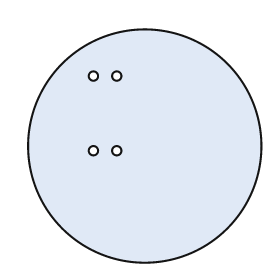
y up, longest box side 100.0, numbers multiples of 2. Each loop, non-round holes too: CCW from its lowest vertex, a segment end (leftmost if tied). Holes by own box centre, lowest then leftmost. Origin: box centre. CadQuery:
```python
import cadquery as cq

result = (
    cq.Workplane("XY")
    .moveTo(0.0, 0.0)
    .circle(50.0)
    .moveTo(-22.0, -2.0)
    .circle(2.0)
    .moveTo(-12.0, -2.0)
    .circle(2.0)
    .moveTo(-22.0, 30.0)
    .circle(2.0)
    .moveTo(-12.0, 30.0)
    .circle(2.0)
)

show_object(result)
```